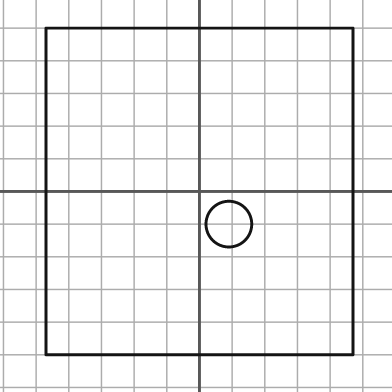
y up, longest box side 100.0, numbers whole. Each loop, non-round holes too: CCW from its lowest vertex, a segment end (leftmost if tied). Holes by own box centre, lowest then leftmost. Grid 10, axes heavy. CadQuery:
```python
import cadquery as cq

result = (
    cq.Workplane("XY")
    .moveTo(-47.0, -50.0)
    .lineTo(47.0, -50.0)
    .lineTo(47.0, 50.0)
    .lineTo(-47.0, 50.0)
    .close()
    .moveTo(9.0, -10.0)
    .circle(7.0)
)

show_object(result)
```